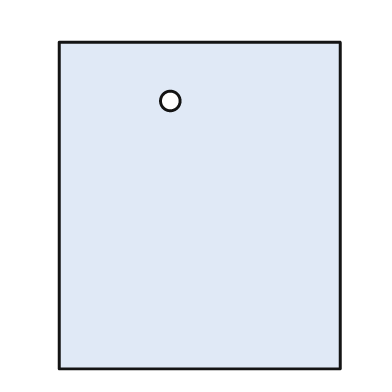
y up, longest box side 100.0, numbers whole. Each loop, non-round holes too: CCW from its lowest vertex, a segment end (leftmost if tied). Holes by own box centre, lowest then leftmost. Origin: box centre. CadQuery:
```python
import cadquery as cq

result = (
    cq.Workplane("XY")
    .moveTo(-43.0, -50.0)
    .lineTo(43.0, -50.0)
    .lineTo(43.0, 50.0)
    .lineTo(-43.0, 50.0)
    .close()
    .moveTo(-9.0, 32.0)
    .circle(3.0)
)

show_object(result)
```